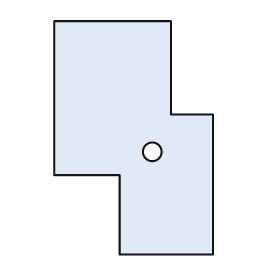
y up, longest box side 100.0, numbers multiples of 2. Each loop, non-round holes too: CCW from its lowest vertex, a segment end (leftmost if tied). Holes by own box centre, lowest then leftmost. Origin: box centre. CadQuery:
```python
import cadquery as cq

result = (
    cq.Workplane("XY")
    .moveTo(-6.0, -50.0)
    .lineTo(34.0, -50.0)
    .lineTo(34.0, 10.0)
    .lineTo(16.0, 10.0)
    .lineTo(16.0, 50.0)
    .lineTo(-34.0, 50.0)
    .lineTo(-34.0, -16.0)
    .lineTo(-6.0, -16.0)
    .close()
    .moveTo(8.0, -6.0)
    .circle(4.0)
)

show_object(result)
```